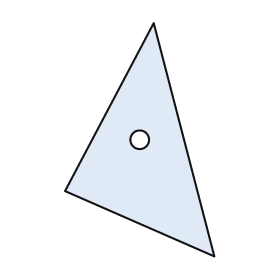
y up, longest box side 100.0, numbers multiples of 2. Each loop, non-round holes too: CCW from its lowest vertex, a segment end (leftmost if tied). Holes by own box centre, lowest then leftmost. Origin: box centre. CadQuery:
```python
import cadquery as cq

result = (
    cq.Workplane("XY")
    .moveTo(32.0, -50.0)
    .lineTo(6.0, 50.0)
    .lineTo(-32.0, -22.0)
    .close()
    .moveTo(0.0, 0.0)
    .circle(4.0)
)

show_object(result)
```